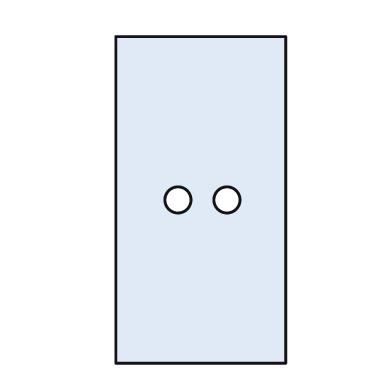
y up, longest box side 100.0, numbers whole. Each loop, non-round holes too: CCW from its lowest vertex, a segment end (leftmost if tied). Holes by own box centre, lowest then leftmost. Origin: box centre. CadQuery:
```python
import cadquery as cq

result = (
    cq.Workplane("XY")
    .moveTo(-26.0, -50.0)
    .lineTo(26.0, -50.0)
    .lineTo(26.0, 50.0)
    .lineTo(-26.0, 50.0)
    .close()
    .moveTo(-7.0, 0.0)
    .circle(4.0)
    .moveTo(8.0, 0.0)
    .circle(4.0)
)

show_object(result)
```